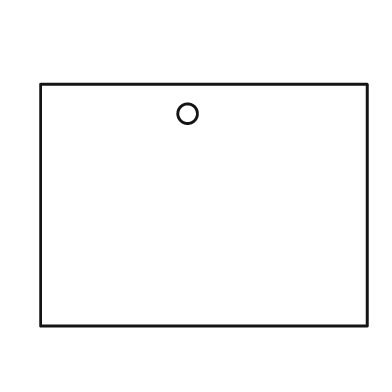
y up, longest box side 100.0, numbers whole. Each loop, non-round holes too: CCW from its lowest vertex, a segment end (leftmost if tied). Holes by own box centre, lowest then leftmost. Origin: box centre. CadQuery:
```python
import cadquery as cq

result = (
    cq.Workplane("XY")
    .moveTo(-50.0, -37.0)
    .lineTo(50.0, -37.0)
    .lineTo(50.0, 37.0)
    .lineTo(-50.0, 37.0)
    .close()
    .moveTo(-5.0, 28.0)
    .circle(3.0)
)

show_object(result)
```